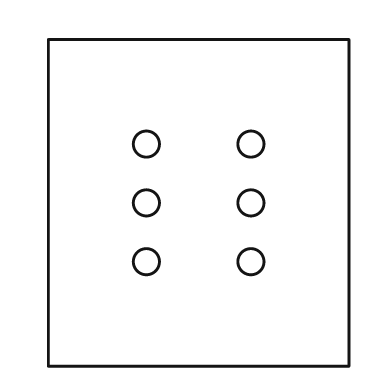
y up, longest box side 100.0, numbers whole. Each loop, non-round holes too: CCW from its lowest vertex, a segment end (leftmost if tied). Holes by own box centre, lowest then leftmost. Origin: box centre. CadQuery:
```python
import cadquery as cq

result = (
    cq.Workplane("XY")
    .moveTo(-46.0, -50.0)
    .lineTo(46.0, -50.0)
    .lineTo(46.0, 50.0)
    .lineTo(-46.0, 50.0)
    .close()
    .moveTo(-16.0, -18.0)
    .circle(4.0)
    .moveTo(16.0, -18.0)
    .circle(4.0)
    .moveTo(-16.0, 0.0)
    .circle(4.0)
    .moveTo(16.0, 0.0)
    .circle(4.0)
    .moveTo(-16.0, 18.0)
    .circle(4.0)
    .moveTo(16.0, 18.0)
    .circle(4.0)
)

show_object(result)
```